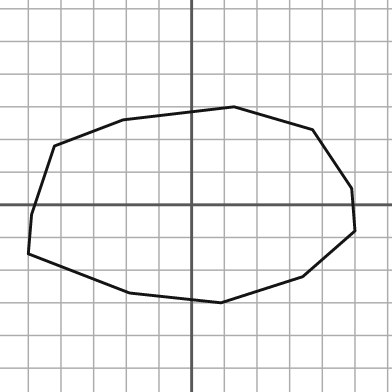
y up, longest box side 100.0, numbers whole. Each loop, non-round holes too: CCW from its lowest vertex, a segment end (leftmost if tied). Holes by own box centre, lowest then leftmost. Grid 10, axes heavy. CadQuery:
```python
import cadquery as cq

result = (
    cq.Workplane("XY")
    .moveTo(9.0, -30.0)
    .lineTo(34.0, -22.0)
    .lineTo(50.0, -8.0)
    .lineTo(49.0, 5.0)
    .lineTo(37.0, 23.0)
    .lineTo(13.0, 30.0)
    .lineTo(-21.0, 26.0)
    .lineTo(-42.0, 18.0)
    .lineTo(-49.0, -3.0)
    .lineTo(-50.0, -15.0)
    .lineTo(-19.0, -27.0)
    .close()
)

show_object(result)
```